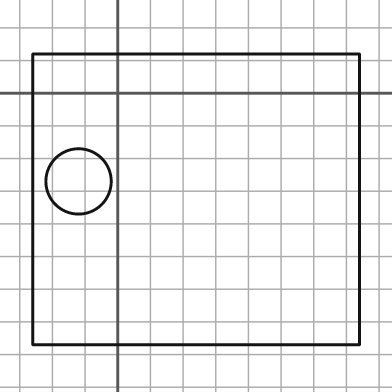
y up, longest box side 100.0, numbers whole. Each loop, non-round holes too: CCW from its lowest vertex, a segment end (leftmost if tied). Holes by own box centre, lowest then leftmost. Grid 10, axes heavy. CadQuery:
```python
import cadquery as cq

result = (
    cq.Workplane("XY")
    .moveTo(-26.0, -77.0)
    .lineTo(74.0, -77.0)
    .lineTo(74.0, 12.0)
    .lineTo(-26.0, 12.0)
    .close()
    .moveTo(-12.0, -27.0)
    .circle(10.0)
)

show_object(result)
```